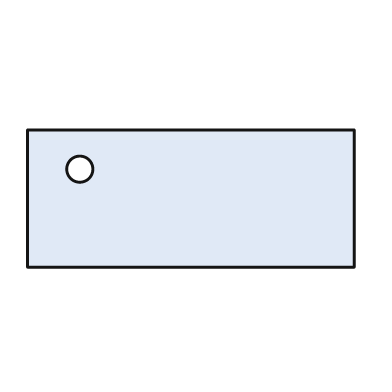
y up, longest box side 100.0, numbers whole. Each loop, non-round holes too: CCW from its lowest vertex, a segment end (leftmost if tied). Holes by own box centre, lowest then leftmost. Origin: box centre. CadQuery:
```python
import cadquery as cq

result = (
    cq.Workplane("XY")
    .moveTo(-50.0, -21.0)
    .lineTo(50.0, -21.0)
    .lineTo(50.0, 21.0)
    .lineTo(-50.0, 21.0)
    .close()
    .moveTo(-34.0, 9.0)
    .circle(4.0)
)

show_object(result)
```